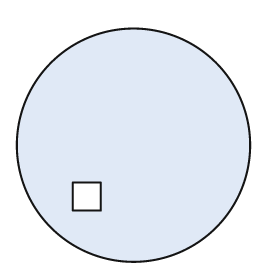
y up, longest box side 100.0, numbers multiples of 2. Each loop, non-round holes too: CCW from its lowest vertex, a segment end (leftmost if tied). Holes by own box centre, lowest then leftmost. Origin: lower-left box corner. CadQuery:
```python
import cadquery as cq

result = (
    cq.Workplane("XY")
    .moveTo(50.0, 50.0)
    .circle(50.0)
    .moveTo(24.0, 22.0)
    .lineTo(36.0, 22.0)
    .lineTo(36.0, 34.0)
    .lineTo(24.0, 34.0)
    .close()
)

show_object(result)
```